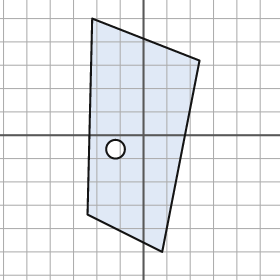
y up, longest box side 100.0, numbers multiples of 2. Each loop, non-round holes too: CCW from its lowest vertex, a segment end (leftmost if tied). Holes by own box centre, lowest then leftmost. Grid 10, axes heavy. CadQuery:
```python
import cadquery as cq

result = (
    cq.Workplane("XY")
    .moveTo(8.0, -50.0)
    .lineTo(24.0, 32.0)
    .lineTo(-22.0, 50.0)
    .lineTo(-24.0, -34.0)
    .close()
    .moveTo(-12.0, -6.0)
    .circle(4.0)
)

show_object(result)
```